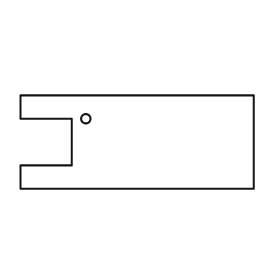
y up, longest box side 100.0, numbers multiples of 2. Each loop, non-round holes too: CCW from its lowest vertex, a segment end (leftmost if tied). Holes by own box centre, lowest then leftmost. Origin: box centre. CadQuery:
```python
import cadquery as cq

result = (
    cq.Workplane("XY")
    .moveTo(-50.0, -20.0)
    .lineTo(50.0, -20.0)
    .lineTo(50.0, 20.0)
    .lineTo(-50.0, 20.0)
    .lineTo(-50.0, 10.0)
    .lineTo(-28.0, 10.0)
    .lineTo(-28.0, -10.0)
    .lineTo(-50.0, -10.0)
    .close()
    .moveTo(-22.0, 10.0)
    .circle(2.0)
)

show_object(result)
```